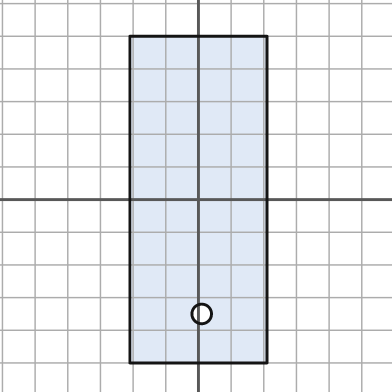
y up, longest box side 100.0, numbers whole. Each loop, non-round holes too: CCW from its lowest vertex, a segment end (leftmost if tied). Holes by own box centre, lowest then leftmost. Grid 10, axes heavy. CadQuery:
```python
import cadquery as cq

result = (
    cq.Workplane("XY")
    .moveTo(-21.0, -50.0)
    .lineTo(21.0, -50.0)
    .lineTo(21.0, 50.0)
    .lineTo(-21.0, 50.0)
    .close()
    .moveTo(1.0, -35.0)
    .circle(3.0)
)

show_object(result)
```